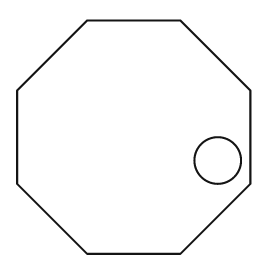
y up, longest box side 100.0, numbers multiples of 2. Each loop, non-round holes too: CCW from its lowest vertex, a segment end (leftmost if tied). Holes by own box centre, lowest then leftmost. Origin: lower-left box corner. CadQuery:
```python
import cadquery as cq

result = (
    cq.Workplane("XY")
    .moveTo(30.0, 0.0)
    .lineTo(70.0, 0.0)
    .lineTo(100.0, 30.0)
    .lineTo(100.0, 70.0)
    .lineTo(70.0, 100.0)
    .lineTo(30.0, 100.0)
    .lineTo(0.0, 70.0)
    .lineTo(0.0, 30.0)
    .close()
    .moveTo(86.0, 40.0)
    .circle(10.0)
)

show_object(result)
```